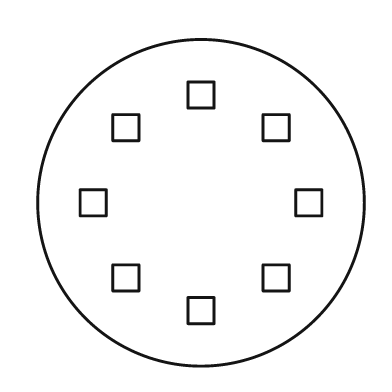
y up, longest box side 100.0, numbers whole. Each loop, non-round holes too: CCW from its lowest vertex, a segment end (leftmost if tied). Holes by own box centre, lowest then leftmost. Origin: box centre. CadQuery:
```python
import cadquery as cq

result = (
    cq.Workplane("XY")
    .moveTo(0.0, 0.0)
    .circle(50.0)
    .moveTo(-4.0, -37.0)
    .lineTo(4.0, -37.0)
    .lineTo(4.0, -29.0)
    .lineTo(-4.0, -29.0)
    .close()
    .moveTo(-27.0, -27.0)
    .lineTo(-19.0, -27.0)
    .lineTo(-19.0, -19.0)
    .lineTo(-27.0, -19.0)
    .close()
    .moveTo(19.0, -27.0)
    .lineTo(27.0, -27.0)
    .lineTo(27.0, -19.0)
    .lineTo(19.0, -19.0)
    .close()
    .moveTo(-37.0, -4.0)
    .lineTo(-29.0, -4.0)
    .lineTo(-29.0, 4.0)
    .lineTo(-37.0, 4.0)
    .close()
    .moveTo(29.0, -4.0)
    .lineTo(37.0, -4.0)
    .lineTo(37.0, 4.0)
    .lineTo(29.0, 4.0)
    .close()
    .moveTo(-27.0, 19.0)
    .lineTo(-19.0, 19.0)
    .lineTo(-19.0, 27.0)
    .lineTo(-27.0, 27.0)
    .close()
    .moveTo(19.0, 19.0)
    .lineTo(27.0, 19.0)
    .lineTo(27.0, 27.0)
    .lineTo(19.0, 27.0)
    .close()
    .moveTo(-4.0, 29.0)
    .lineTo(4.0, 29.0)
    .lineTo(4.0, 37.0)
    .lineTo(-4.0, 37.0)
    .close()
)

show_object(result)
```